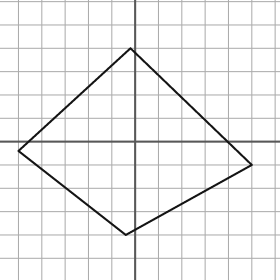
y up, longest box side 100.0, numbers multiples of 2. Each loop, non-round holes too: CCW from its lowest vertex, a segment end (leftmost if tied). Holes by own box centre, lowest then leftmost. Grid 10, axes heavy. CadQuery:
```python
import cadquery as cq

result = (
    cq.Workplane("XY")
    .moveTo(-4.0, -40.0)
    .lineTo(50.0, -10.0)
    .lineTo(-2.0, 40.0)
    .lineTo(-50.0, -4.0)
    .close()
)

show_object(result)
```